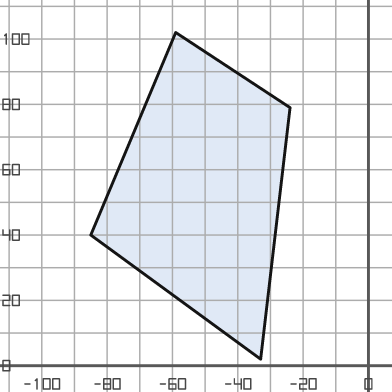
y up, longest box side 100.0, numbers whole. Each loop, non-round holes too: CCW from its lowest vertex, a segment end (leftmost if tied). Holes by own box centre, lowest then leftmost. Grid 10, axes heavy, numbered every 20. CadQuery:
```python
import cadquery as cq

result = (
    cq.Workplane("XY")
    .moveTo(-33.0, 2.0)
    .lineTo(-24.0, 79.0)
    .lineTo(-59.0, 102.0)
    .lineTo(-85.0, 40.0)
    .close()
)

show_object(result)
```